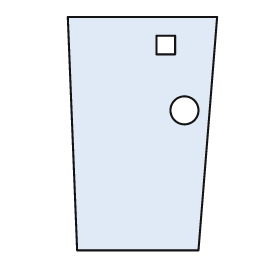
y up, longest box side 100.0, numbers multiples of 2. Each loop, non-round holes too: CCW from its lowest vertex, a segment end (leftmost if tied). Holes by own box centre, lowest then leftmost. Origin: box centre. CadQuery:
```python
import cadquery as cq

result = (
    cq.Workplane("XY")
    .moveTo(-28.0, -50.0)
    .lineTo(24.0, -50.0)
    .lineTo(32.0, 50.0)
    .lineTo(-32.0, 50.0)
    .close()
    .moveTo(18.0, 10.0)
    .circle(6.0)
    .moveTo(6.0, 34.0)
    .lineTo(14.0, 34.0)
    .lineTo(14.0, 42.0)
    .lineTo(6.0, 42.0)
    .close()
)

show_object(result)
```